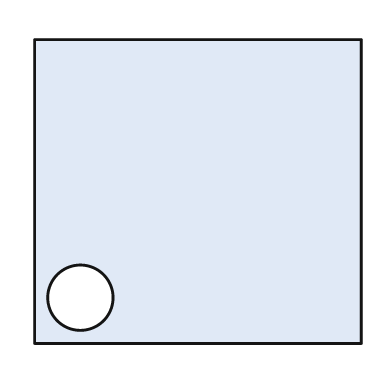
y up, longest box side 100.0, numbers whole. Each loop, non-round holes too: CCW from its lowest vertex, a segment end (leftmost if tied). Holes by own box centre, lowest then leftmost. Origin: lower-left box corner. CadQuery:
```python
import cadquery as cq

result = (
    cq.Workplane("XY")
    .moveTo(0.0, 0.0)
    .lineTo(100.0, 0.0)
    .lineTo(100.0, 93.0)
    .lineTo(0.0, 93.0)
    .close()
    .moveTo(14.0, 14.0)
    .circle(10.0)
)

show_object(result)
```